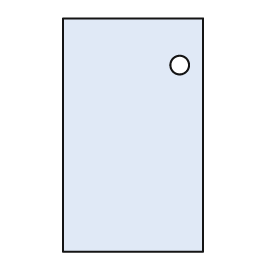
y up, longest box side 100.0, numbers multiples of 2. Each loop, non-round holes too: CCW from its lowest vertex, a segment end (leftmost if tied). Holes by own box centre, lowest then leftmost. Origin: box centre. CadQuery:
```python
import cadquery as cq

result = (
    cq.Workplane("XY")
    .moveTo(-30.0, -50.0)
    .lineTo(30.0, -50.0)
    .lineTo(30.0, 50.0)
    .lineTo(-30.0, 50.0)
    .close()
    .moveTo(20.0, 30.0)
    .circle(4.0)
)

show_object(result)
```